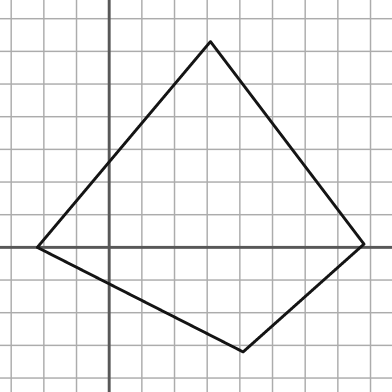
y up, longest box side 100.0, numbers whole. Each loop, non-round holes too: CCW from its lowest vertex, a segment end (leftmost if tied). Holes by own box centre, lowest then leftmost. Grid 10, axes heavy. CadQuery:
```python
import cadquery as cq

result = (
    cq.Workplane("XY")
    .moveTo(41.0, -32.0)
    .lineTo(78.0, 1.0)
    .lineTo(31.0, 63.0)
    .lineTo(-22.0, 0.0)
    .close()
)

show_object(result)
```